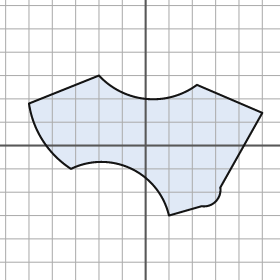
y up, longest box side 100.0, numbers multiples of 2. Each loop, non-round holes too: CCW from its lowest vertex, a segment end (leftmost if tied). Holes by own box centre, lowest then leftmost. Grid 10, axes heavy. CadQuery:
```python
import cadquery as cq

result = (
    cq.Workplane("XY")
    .moveTo(10.0, -30.0)
    .lineTo(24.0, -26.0)
    .threePointArc((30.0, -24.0), (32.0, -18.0))
    .lineTo(50.0, 14.0)
    .lineTo(22.0, 26.0)
    .threePointArc((0.0, 20.0), (-20.0, 30.0))
    .lineTo(-50.0, 18.0)
    .threePointArc((-44.0, 2.0), (-32.0, -10.0))
    .threePointArc((-6.0, -10.0), (10.0, -30.0))
    .close()
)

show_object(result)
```